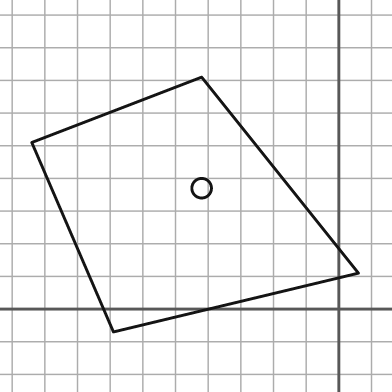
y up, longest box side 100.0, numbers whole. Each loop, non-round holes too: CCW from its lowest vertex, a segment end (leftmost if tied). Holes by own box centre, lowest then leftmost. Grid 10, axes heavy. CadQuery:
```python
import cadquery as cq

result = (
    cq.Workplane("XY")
    .moveTo(-69.0, -7.0)
    .lineTo(6.0, 11.0)
    .lineTo(-42.0, 71.0)
    .lineTo(-94.0, 51.0)
    .close()
    .moveTo(-42.0, 37.0)
    .circle(3.0)
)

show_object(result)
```